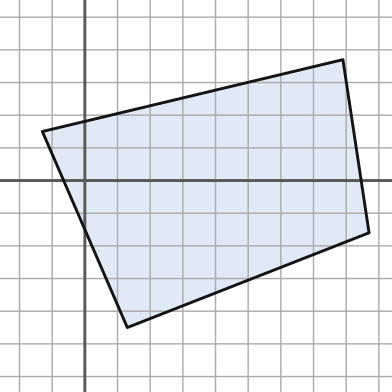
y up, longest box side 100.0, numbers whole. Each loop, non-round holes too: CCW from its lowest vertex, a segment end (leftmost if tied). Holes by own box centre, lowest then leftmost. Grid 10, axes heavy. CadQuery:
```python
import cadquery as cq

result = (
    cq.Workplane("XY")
    .moveTo(13.0, -45.0)
    .lineTo(87.0, -16.0)
    .lineTo(79.0, 37.0)
    .lineTo(-13.0, 15.0)
    .close()
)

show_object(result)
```